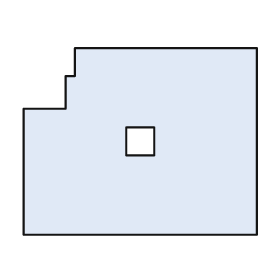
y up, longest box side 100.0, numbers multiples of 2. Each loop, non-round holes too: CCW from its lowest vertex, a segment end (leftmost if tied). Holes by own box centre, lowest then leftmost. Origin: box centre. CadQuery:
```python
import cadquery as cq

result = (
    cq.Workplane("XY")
    .moveTo(-50.0, -40.0)
    .lineTo(50.0, -40.0)
    .lineTo(50.0, 40.0)
    .lineTo(-28.0, 40.0)
    .lineTo(-28.0, 28.0)
    .lineTo(-32.0, 28.0)
    .lineTo(-32.0, 14.0)
    .lineTo(-50.0, 14.0)
    .close()
    .moveTo(-6.0, -6.0)
    .lineTo(6.0, -6.0)
    .lineTo(6.0, 6.0)
    .lineTo(-6.0, 6.0)
    .close()
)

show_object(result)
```